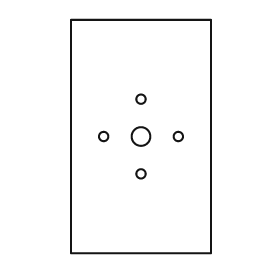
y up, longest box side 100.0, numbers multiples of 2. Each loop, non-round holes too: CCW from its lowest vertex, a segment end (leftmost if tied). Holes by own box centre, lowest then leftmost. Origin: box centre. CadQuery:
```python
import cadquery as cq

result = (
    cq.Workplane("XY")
    .moveTo(-30.0, -50.0)
    .lineTo(30.0, -50.0)
    .lineTo(30.0, 50.0)
    .lineTo(-30.0, 50.0)
    .close()
    .moveTo(0.0, -16.0)
    .circle(2.0)
    .moveTo(-16.0, 0.0)
    .circle(2.0)
    .moveTo(0.0, 0.0)
    .circle(4.0)
    .moveTo(16.0, 0.0)
    .circle(2.0)
    .moveTo(0.0, 16.0)
    .circle(2.0)
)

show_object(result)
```